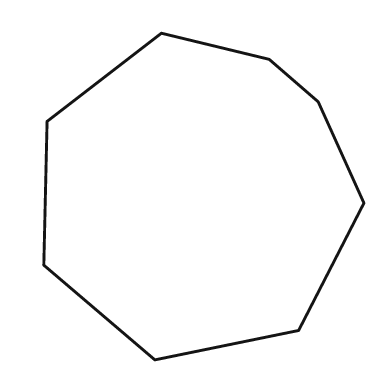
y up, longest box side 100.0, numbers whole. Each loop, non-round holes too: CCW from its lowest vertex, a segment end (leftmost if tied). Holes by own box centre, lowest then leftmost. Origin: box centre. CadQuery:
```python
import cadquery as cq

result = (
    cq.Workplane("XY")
    .moveTo(-15.0, -50.0)
    .lineTo(29.0, -41.0)
    .lineTo(49.0, -2.0)
    .lineTo(35.0, 29.0)
    .lineTo(20.0, 42.0)
    .lineTo(-13.0, 50.0)
    .lineTo(-48.0, 23.0)
    .lineTo(-49.0, -21.0)
    .close()
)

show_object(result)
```